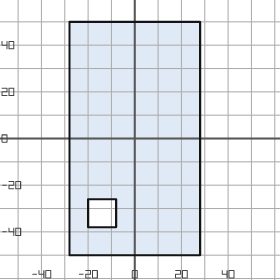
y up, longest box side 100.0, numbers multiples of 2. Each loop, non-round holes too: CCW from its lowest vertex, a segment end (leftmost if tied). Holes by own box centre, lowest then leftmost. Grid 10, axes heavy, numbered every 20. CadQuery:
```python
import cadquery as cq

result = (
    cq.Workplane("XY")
    .moveTo(-28.0, -50.0)
    .lineTo(28.0, -50.0)
    .lineTo(28.0, 50.0)
    .lineTo(-28.0, 50.0)
    .close()
    .moveTo(-20.0, -38.0)
    .lineTo(-8.0, -38.0)
    .lineTo(-8.0, -26.0)
    .lineTo(-20.0, -26.0)
    .close()
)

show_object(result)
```